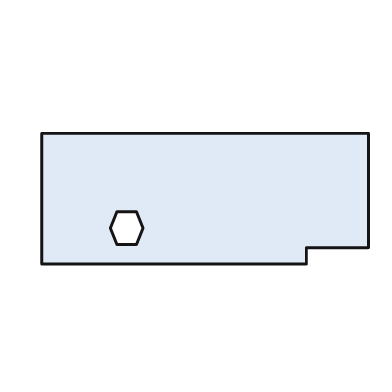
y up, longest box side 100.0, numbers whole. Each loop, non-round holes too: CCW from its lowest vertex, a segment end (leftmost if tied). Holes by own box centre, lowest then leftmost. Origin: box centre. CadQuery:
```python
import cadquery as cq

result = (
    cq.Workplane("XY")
    .moveTo(-50.0, -20.0)
    .lineTo(31.0, -20.0)
    .lineTo(31.0, -15.0)
    .lineTo(50.0, -15.0)
    .lineTo(50.0, 20.0)
    .lineTo(-50.0, 20.0)
    .close()
    .moveTo(-27.0, -14.0)
    .lineTo(-21.0, -14.0)
    .lineTo(-19.0, -9.0)
    .lineTo(-21.0, -4.0)
    .lineTo(-27.0, -4.0)
    .lineTo(-29.0, -9.0)
    .close()
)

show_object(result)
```